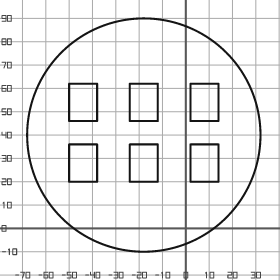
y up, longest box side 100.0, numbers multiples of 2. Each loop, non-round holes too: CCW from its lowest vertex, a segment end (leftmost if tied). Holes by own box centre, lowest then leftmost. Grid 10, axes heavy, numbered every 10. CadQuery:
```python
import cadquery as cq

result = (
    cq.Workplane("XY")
    .moveTo(-18.0, 40.0)
    .circle(50.0)
    .moveTo(-50.0, 20.0)
    .lineTo(-38.0, 20.0)
    .lineTo(-38.0, 36.0)
    .lineTo(-50.0, 36.0)
    .close()
    .moveTo(-24.0, 20.0)
    .lineTo(-12.0, 20.0)
    .lineTo(-12.0, 36.0)
    .lineTo(-24.0, 36.0)
    .close()
    .moveTo(2.0, 20.0)
    .lineTo(14.0, 20.0)
    .lineTo(14.0, 36.0)
    .lineTo(2.0, 36.0)
    .close()
    .moveTo(-50.0, 46.0)
    .lineTo(-38.0, 46.0)
    .lineTo(-38.0, 62.0)
    .lineTo(-50.0, 62.0)
    .close()
    .moveTo(-24.0, 46.0)
    .lineTo(-12.0, 46.0)
    .lineTo(-12.0, 62.0)
    .lineTo(-24.0, 62.0)
    .close()
    .moveTo(2.0, 46.0)
    .lineTo(14.0, 46.0)
    .lineTo(14.0, 62.0)
    .lineTo(2.0, 62.0)
    .close()
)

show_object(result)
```